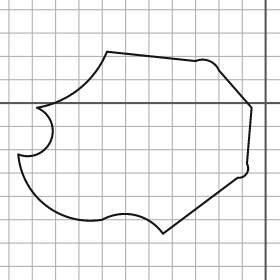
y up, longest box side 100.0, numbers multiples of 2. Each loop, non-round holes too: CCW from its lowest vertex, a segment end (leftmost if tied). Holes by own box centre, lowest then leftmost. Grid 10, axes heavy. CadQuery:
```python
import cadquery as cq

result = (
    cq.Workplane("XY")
    .moveTo(-44.0, -56.0)
    .lineTo(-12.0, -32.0)
    .threePointArc((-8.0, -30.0), (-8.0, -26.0))
    .lineTo(-6.0, -2.0)
    .lineTo(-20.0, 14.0)
    .threePointArc((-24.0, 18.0), (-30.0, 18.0))
    .lineTo(-68.0, 22.0)
    .threePointArc((-80.0, 6.0), (-98.0, -2.0))
    .threePointArc((-92.0, -16.0), (-106.0, -22.0))
    .threePointArc((-94.0, -44.0), (-70.0, -50.0))
    .threePointArc((-56.0, -48.0), (-44.0, -56.0))
    .close()
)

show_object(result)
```